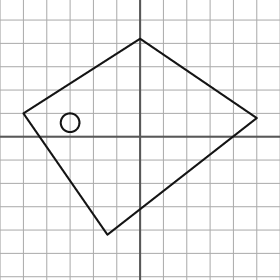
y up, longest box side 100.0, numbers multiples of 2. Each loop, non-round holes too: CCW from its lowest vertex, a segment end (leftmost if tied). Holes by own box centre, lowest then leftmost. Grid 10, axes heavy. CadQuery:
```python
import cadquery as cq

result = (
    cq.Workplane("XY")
    .moveTo(-14.0, -42.0)
    .lineTo(50.0, 8.0)
    .lineTo(0.0, 42.0)
    .lineTo(-50.0, 10.0)
    .close()
    .moveTo(-30.0, 6.0)
    .circle(4.0)
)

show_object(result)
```